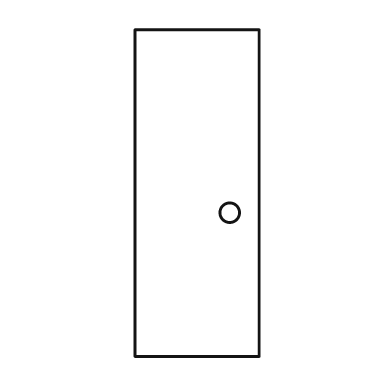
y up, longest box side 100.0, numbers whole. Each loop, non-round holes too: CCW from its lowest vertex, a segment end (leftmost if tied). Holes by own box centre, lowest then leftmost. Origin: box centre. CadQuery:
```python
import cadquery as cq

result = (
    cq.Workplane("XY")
    .moveTo(-19.0, -50.0)
    .lineTo(19.0, -50.0)
    .lineTo(19.0, 50.0)
    .lineTo(-19.0, 50.0)
    .close()
    .moveTo(10.0, -6.0)
    .circle(3.0)
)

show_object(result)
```